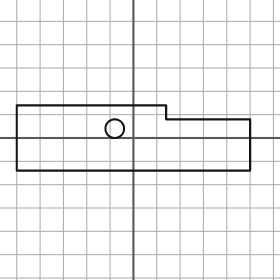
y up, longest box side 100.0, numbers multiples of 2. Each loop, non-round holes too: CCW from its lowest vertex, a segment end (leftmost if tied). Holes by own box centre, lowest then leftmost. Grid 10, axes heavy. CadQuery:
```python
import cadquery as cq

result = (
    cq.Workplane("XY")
    .moveTo(-50.0, -14.0)
    .lineTo(50.0, -14.0)
    .lineTo(50.0, 8.0)
    .lineTo(14.0, 8.0)
    .lineTo(14.0, 14.0)
    .lineTo(-50.0, 14.0)
    .close()
    .moveTo(-8.0, 4.0)
    .circle(4.0)
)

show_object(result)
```